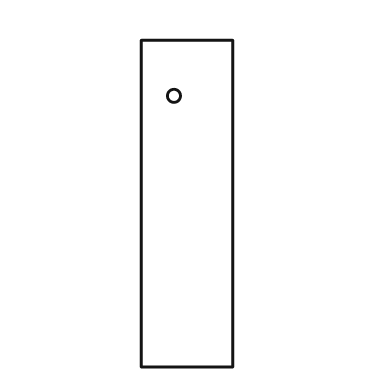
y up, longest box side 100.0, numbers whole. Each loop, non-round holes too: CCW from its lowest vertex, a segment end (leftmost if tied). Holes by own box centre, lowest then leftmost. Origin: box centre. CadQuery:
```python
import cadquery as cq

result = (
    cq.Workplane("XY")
    .moveTo(-14.0, -50.0)
    .lineTo(14.0, -50.0)
    .lineTo(14.0, 50.0)
    .lineTo(-14.0, 50.0)
    .close()
    .moveTo(-4.0, 33.0)
    .circle(2.0)
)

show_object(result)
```